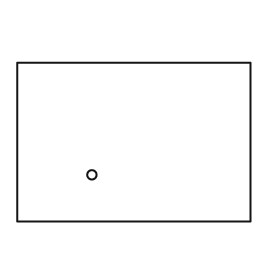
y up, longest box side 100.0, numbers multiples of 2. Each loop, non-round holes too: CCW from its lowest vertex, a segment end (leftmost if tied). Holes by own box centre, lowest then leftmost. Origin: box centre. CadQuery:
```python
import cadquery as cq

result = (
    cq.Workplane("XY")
    .moveTo(-50.0, -34.0)
    .lineTo(50.0, -34.0)
    .lineTo(50.0, 34.0)
    .lineTo(-50.0, 34.0)
    .close()
    .moveTo(-18.0, -14.0)
    .circle(2.0)
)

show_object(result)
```